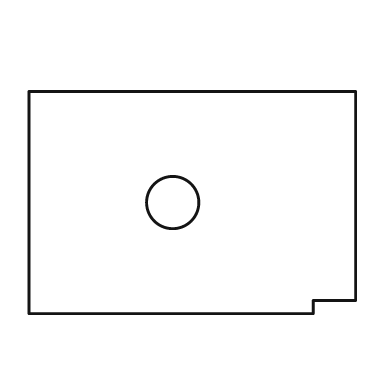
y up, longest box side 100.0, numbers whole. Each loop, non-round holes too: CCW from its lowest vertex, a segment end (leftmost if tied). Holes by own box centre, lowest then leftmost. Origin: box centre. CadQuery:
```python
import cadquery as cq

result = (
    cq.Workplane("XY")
    .moveTo(-50.0, -34.0)
    .lineTo(37.0, -34.0)
    .lineTo(37.0, -30.0)
    .lineTo(50.0, -30.0)
    .lineTo(50.0, 34.0)
    .lineTo(-50.0, 34.0)
    .close()
    .moveTo(-6.0, 0.0)
    .circle(8.0)
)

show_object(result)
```